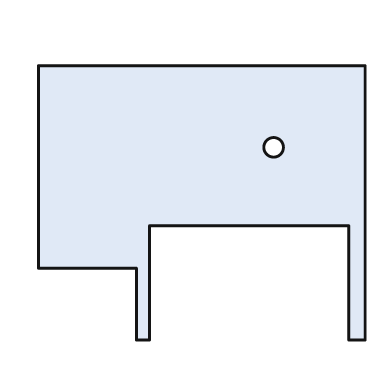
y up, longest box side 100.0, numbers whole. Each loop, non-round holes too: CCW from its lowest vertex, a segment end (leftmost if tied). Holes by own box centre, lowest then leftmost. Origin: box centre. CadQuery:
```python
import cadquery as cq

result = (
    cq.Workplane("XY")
    .moveTo(-20.0, -42.0)
    .lineTo(-16.0, -42.0)
    .lineTo(-16.0, -7.0)
    .lineTo(45.0, -7.0)
    .lineTo(45.0, -42.0)
    .lineTo(50.0, -42.0)
    .lineTo(50.0, 42.0)
    .lineTo(-50.0, 42.0)
    .lineTo(-50.0, -20.0)
    .lineTo(-20.0, -20.0)
    .close()
    .moveTo(22.0, 17.0)
    .circle(3.0)
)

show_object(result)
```